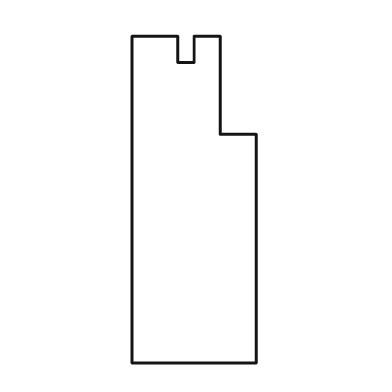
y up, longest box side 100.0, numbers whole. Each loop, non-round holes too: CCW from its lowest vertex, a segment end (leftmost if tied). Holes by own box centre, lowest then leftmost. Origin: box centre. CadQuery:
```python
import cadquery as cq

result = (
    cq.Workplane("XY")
    .moveTo(-19.0, -50.0)
    .lineTo(19.0, -50.0)
    .lineTo(19.0, 20.0)
    .lineTo(8.0, 20.0)
    .lineTo(8.0, 50.0)
    .lineTo(0.0, 50.0)
    .lineTo(0.0, 42.0)
    .lineTo(-5.0, 42.0)
    .lineTo(-5.0, 50.0)
    .lineTo(-19.0, 50.0)
    .close()
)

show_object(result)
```